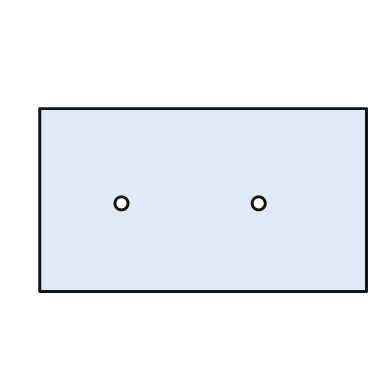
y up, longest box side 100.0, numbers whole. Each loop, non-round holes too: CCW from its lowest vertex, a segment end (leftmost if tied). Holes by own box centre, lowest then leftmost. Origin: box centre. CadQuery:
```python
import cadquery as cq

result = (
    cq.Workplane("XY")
    .moveTo(-50.0, -28.0)
    .lineTo(50.0, -28.0)
    .lineTo(50.0, 28.0)
    .lineTo(-50.0, 28.0)
    .close()
    .moveTo(-25.0, -1.0)
    .circle(2.0)
    .moveTo(17.0, -1.0)
    .circle(2.0)
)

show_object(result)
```